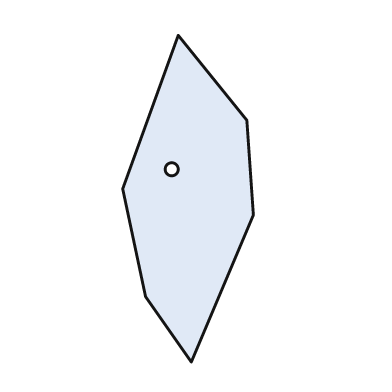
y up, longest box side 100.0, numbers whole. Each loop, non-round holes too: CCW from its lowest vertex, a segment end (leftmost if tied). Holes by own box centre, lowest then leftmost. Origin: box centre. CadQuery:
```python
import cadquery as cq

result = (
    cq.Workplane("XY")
    .moveTo(1.0, -50.0)
    .lineTo(20.0, -5.0)
    .lineTo(18.0, 24.0)
    .lineTo(-3.0, 50.0)
    .lineTo(-20.0, 3.0)
    .lineTo(-13.0, -30.0)
    .close()
    .moveTo(-5.0, 9.0)
    .circle(2.0)
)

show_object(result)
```